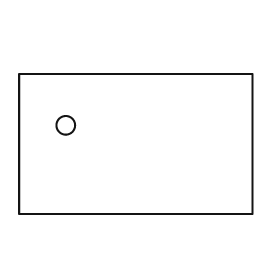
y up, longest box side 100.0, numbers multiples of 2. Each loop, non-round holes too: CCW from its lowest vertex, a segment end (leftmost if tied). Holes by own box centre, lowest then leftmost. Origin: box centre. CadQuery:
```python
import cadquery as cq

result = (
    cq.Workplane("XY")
    .moveTo(-50.0, -30.0)
    .lineTo(50.0, -30.0)
    .lineTo(50.0, 30.0)
    .lineTo(-50.0, 30.0)
    .close()
    .moveTo(-30.0, 8.0)
    .circle(4.0)
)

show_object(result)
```